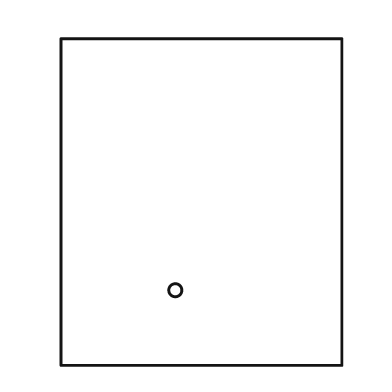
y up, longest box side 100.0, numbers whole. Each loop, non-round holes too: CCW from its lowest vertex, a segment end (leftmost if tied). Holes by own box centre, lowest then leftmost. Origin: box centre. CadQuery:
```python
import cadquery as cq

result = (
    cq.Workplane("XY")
    .moveTo(-43.0, -50.0)
    .lineTo(43.0, -50.0)
    .lineTo(43.0, 50.0)
    .lineTo(-43.0, 50.0)
    .close()
    .moveTo(-8.0, -27.0)
    .circle(2.0)
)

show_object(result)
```